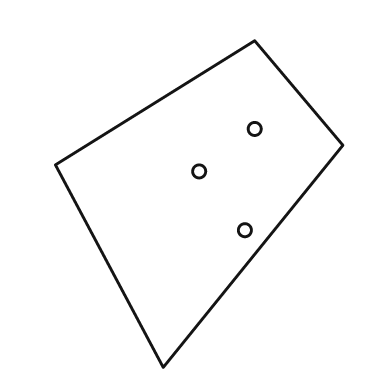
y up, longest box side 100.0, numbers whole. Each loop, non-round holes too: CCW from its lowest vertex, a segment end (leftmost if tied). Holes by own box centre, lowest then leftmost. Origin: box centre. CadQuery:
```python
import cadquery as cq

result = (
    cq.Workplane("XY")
    .moveTo(-11.0, -50.0)
    .lineTo(44.0, 18.0)
    .lineTo(17.0, 50.0)
    .lineTo(-44.0, 12.0)
    .close()
    .moveTo(14.0, -8.0)
    .circle(2.0)
    .moveTo(0.0, 10.0)
    .circle(2.0)
    .moveTo(17.0, 23.0)
    .circle(2.0)
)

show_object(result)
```